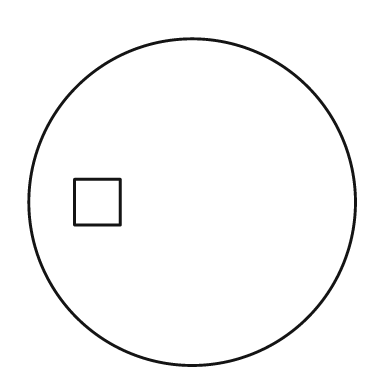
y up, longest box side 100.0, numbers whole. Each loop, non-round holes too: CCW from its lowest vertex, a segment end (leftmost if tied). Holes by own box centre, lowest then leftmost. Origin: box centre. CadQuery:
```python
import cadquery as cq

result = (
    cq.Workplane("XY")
    .moveTo(0.0, 0.0)
    .circle(50.0)
    .moveTo(-36.0, -7.0)
    .lineTo(-22.0, -7.0)
    .lineTo(-22.0, 7.0)
    .lineTo(-36.0, 7.0)
    .close()
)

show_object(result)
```